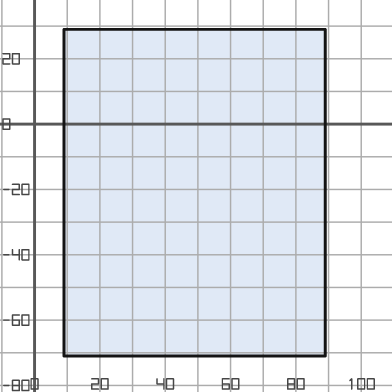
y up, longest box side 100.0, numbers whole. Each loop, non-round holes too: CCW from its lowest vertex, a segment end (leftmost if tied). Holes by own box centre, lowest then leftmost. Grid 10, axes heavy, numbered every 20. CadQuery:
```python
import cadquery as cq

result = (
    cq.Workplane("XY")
    .moveTo(9.0, -71.0)
    .lineTo(89.0, -71.0)
    .lineTo(89.0, 29.0)
    .lineTo(9.0, 29.0)
    .close()
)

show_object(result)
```